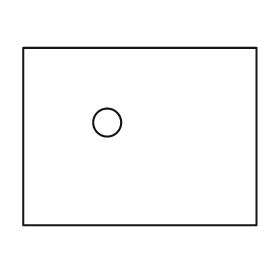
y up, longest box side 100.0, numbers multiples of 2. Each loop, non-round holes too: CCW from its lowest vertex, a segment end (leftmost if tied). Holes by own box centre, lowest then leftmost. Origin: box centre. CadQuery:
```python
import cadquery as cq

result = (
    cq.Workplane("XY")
    .moveTo(-50.0, -38.0)
    .lineTo(50.0, -38.0)
    .lineTo(50.0, 38.0)
    .lineTo(-50.0, 38.0)
    .close()
    .moveTo(-14.0, 6.0)
    .circle(6.0)
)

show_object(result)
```